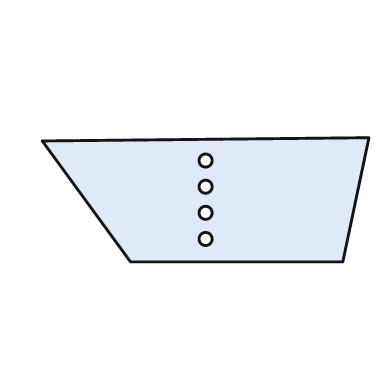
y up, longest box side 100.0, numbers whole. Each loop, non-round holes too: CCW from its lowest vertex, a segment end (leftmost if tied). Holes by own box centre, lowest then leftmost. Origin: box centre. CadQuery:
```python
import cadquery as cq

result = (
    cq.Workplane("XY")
    .moveTo(-23.0, -19.0)
    .lineTo(42.0, -19.0)
    .lineTo(50.0, 19.0)
    .lineTo(-50.0, 18.0)
    .close()
    .moveTo(0.0, -12.0)
    .circle(2.0)
    .moveTo(0.0, -4.0)
    .circle(2.0)
    .moveTo(0.0, 4.0)
    .circle(2.0)
    .moveTo(0.0, 12.0)
    .circle(2.0)
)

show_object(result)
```